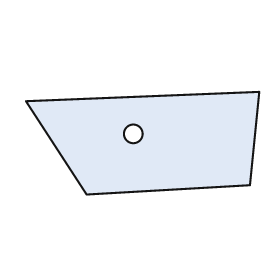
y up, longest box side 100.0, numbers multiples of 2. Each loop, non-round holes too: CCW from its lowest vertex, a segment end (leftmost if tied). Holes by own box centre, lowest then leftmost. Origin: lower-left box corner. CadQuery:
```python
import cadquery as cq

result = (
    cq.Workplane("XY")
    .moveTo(26.0, 0.0)
    .lineTo(96.0, 4.0)
    .lineTo(100.0, 44.0)
    .lineTo(0.0, 40.0)
    .close()
    .moveTo(46.0, 26.0)
    .circle(4.0)
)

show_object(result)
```